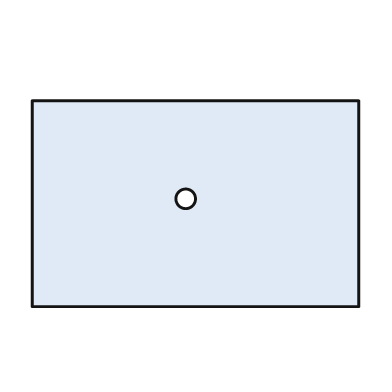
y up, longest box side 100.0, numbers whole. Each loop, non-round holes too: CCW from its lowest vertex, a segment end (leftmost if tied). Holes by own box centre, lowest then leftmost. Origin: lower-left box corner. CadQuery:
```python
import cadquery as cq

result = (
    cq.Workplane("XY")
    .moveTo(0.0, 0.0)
    .lineTo(100.0, 0.0)
    .lineTo(100.0, 63.0)
    .lineTo(0.0, 63.0)
    .close()
    .moveTo(47.0, 33.0)
    .circle(3.0)
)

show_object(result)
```